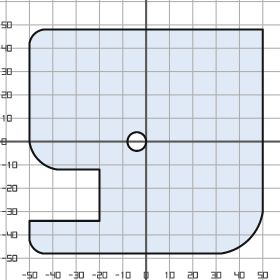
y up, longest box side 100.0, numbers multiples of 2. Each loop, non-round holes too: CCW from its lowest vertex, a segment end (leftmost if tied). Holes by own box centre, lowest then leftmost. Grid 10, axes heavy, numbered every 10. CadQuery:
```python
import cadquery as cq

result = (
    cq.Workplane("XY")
    .moveTo(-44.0, -48.0)
    .lineTo(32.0, -48.0)
    .threePointArc((44.0, -42.0), (50.0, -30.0))
    .lineTo(50.0, 48.0)
    .lineTo(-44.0, 48.0)
    .threePointArc((-48.0, 46.0), (-50.0, 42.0))
    .lineTo(-50.0, 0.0)
    .threePointArc((-46.0, -8.0), (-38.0, -12.0))
    .lineTo(-20.0, -12.0)
    .lineTo(-20.0, -34.0)
    .lineTo(-50.0, -34.0)
    .lineTo(-50.0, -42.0)
    .threePointArc((-48.0, -46.0), (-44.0, -48.0))
    .close()
    .moveTo(-4.0, 0.0)
    .circle(4.0)
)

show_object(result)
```